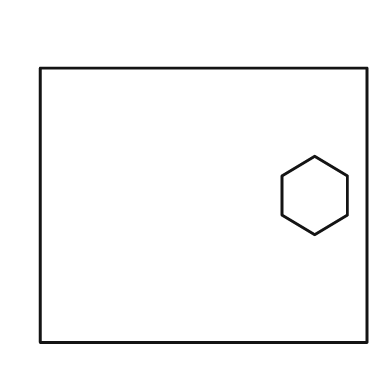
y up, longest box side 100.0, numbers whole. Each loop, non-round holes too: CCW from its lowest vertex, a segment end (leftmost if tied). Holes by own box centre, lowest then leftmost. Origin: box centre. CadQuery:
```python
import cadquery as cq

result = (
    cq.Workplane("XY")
    .moveTo(-50.0, -42.0)
    .lineTo(50.0, -42.0)
    .lineTo(50.0, 42.0)
    .lineTo(-50.0, 42.0)
    .close()
    .moveTo(34.0, -9.0)
    .lineTo(44.0, -3.0)
    .lineTo(44.0, 9.0)
    .lineTo(34.0, 15.0)
    .lineTo(24.0, 9.0)
    .lineTo(24.0, -3.0)
    .close()
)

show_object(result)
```